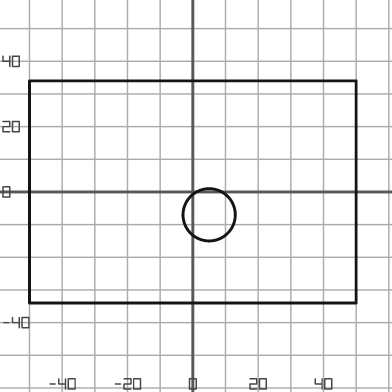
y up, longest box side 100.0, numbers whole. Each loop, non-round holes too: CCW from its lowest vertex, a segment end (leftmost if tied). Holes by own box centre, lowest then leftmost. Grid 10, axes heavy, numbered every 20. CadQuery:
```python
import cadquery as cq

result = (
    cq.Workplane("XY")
    .moveTo(-50.0, -34.0)
    .lineTo(50.0, -34.0)
    .lineTo(50.0, 34.0)
    .lineTo(-50.0, 34.0)
    .close()
    .moveTo(5.0, -7.0)
    .circle(8.0)
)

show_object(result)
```